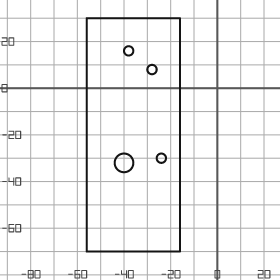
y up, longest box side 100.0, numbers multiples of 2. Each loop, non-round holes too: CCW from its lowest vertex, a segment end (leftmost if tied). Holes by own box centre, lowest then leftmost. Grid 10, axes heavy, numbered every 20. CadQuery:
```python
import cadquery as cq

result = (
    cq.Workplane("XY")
    .moveTo(-56.0, -70.0)
    .lineTo(-16.0, -70.0)
    .lineTo(-16.0, 30.0)
    .lineTo(-56.0, 30.0)
    .close()
    .moveTo(-40.0, -32.0)
    .circle(4.0)
    .moveTo(-24.0, -30.0)
    .circle(2.0)
    .moveTo(-28.0, 8.0)
    .circle(2.0)
    .moveTo(-38.0, 16.0)
    .circle(2.0)
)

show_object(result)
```